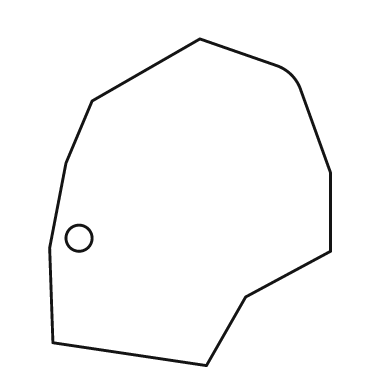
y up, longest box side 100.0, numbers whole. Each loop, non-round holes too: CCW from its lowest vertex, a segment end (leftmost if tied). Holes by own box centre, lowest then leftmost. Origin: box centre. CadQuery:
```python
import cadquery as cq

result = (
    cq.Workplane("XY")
    .moveTo(5.0, -50.0)
    .lineTo(17.0, -29.0)
    .lineTo(43.0, -15.0)
    .lineTo(43.0, 9.0)
    .lineTo(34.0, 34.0)
    .threePointArc((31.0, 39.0), (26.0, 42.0))
    .lineTo(3.0, 50.0)
    .lineTo(-30.0, 31.0)
    .lineTo(-38.0, 12.0)
    .lineTo(-43.0, -14.0)
    .lineTo(-42.0, -43.0)
    .close()
    .moveTo(-34.0, -11.0)
    .circle(4.0)
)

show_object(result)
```